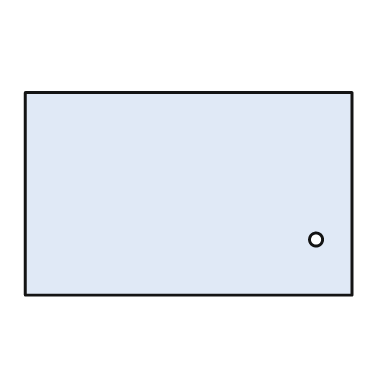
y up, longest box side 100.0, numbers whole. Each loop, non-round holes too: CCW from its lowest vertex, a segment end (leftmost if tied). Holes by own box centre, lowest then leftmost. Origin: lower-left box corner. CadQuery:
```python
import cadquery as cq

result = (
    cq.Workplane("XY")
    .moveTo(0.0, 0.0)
    .lineTo(100.0, 0.0)
    .lineTo(100.0, 62.0)
    .lineTo(0.0, 62.0)
    .close()
    .moveTo(89.0, 17.0)
    .circle(2.0)
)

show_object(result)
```